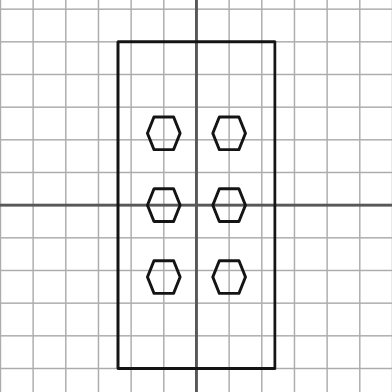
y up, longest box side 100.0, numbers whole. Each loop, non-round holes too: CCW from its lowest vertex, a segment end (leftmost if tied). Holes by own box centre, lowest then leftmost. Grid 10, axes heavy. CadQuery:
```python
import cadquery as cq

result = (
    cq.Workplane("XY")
    .moveTo(-24.0, -50.0)
    .lineTo(24.0, -50.0)
    .lineTo(24.0, 50.0)
    .lineTo(-24.0, 50.0)
    .close()
    .moveTo(-13.0, -27.0)
    .lineTo(-7.0, -27.0)
    .lineTo(-5.0, -22.0)
    .lineTo(-7.0, -17.0)
    .lineTo(-13.0, -17.0)
    .lineTo(-15.0, -22.0)
    .close()
    .moveTo(7.0, -27.0)
    .lineTo(13.0, -27.0)
    .lineTo(15.0, -22.0)
    .lineTo(13.0, -17.0)
    .lineTo(7.0, -17.0)
    .lineTo(5.0, -22.0)
    .close()
    .moveTo(-13.0, -5.0)
    .lineTo(-7.0, -5.0)
    .lineTo(-5.0, 0.0)
    .lineTo(-7.0, 5.0)
    .lineTo(-13.0, 5.0)
    .lineTo(-15.0, 0.0)
    .close()
    .moveTo(7.0, -5.0)
    .lineTo(13.0, -5.0)
    .lineTo(15.0, 0.0)
    .lineTo(13.0, 5.0)
    .lineTo(7.0, 5.0)
    .lineTo(5.0, 0.0)
    .close()
    .moveTo(-13.0, 17.0)
    .lineTo(-7.0, 17.0)
    .lineTo(-5.0, 22.0)
    .lineTo(-7.0, 27.0)
    .lineTo(-13.0, 27.0)
    .lineTo(-15.0, 22.0)
    .close()
    .moveTo(7.0, 17.0)
    .lineTo(13.0, 17.0)
    .lineTo(15.0, 22.0)
    .lineTo(13.0, 27.0)
    .lineTo(7.0, 27.0)
    .lineTo(5.0, 22.0)
    .close()
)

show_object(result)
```